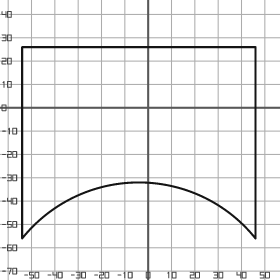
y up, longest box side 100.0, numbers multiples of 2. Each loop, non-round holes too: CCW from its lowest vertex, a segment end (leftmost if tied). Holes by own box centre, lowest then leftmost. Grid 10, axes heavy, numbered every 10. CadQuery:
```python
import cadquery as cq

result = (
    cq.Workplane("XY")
    .moveTo(-54.0, -56.0)
    .threePointArc((-4.0, -32.0), (46.0, -56.0))
    .lineTo(46.0, 26.0)
    .lineTo(-54.0, 26.0)
    .close()
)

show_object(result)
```